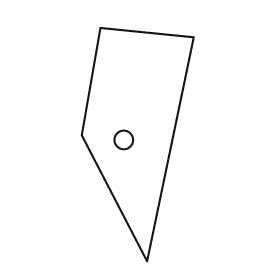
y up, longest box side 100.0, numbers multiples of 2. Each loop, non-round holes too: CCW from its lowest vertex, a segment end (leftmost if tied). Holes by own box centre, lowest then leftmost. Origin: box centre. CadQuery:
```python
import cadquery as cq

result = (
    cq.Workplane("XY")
    .moveTo(4.0, -50.0)
    .lineTo(24.0, 46.0)
    .lineTo(-16.0, 50.0)
    .lineTo(-24.0, 4.0)
    .close()
    .moveTo(-6.0, 2.0)
    .circle(4.0)
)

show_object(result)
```